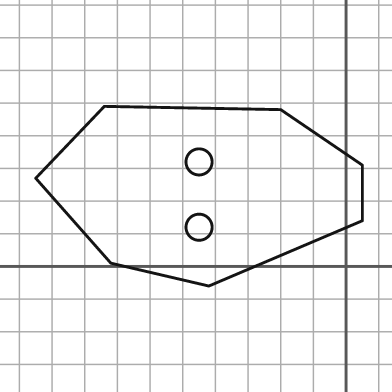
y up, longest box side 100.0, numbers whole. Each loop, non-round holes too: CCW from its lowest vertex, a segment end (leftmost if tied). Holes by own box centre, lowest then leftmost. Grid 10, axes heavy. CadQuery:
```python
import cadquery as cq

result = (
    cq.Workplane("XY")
    .moveTo(-42.0, -6.0)
    .lineTo(5.0, 14.0)
    .lineTo(5.0, 31.0)
    .lineTo(-20.0, 48.0)
    .lineTo(-74.0, 49.0)
    .lineTo(-95.0, 27.0)
    .lineTo(-72.0, 1.0)
    .close()
    .moveTo(-45.0, 12.0)
    .circle(4.0)
    .moveTo(-45.0, 32.0)
    .circle(4.0)
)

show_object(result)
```